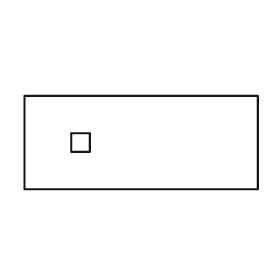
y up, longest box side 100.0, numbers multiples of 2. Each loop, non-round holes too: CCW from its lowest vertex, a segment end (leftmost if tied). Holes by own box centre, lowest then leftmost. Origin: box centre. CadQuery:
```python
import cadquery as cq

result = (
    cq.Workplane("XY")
    .moveTo(-50.0, -20.0)
    .lineTo(50.0, -20.0)
    .lineTo(50.0, 20.0)
    .lineTo(-50.0, 20.0)
    .close()
    .moveTo(-30.0, -4.0)
    .lineTo(-22.0, -4.0)
    .lineTo(-22.0, 4.0)
    .lineTo(-30.0, 4.0)
    .close()
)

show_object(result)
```